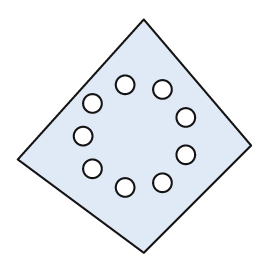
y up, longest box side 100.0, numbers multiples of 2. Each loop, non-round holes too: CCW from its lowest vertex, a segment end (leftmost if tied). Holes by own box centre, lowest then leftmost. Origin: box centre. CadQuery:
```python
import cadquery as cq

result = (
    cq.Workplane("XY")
    .moveTo(4.0, -50.0)
    .lineTo(50.0, -4.0)
    .lineTo(4.0, 50.0)
    .lineTo(-50.0, -10.0)
    .close()
    .moveTo(-4.0, -22.0)
    .circle(4.0)
    .moveTo(12.0, -20.0)
    .circle(4.0)
    .moveTo(-18.0, -14.0)
    .circle(4.0)
    .moveTo(22.0, -8.0)
    .circle(4.0)
    .moveTo(-22.0, 0.0)
    .circle(4.0)
    .moveTo(22.0, 8.0)
    .circle(4.0)
    .moveTo(-18.0, 14.0)
    .circle(4.0)
    .moveTo(12.0, 20.0)
    .circle(4.0)
    .moveTo(-4.0, 22.0)
    .circle(4.0)
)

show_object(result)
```